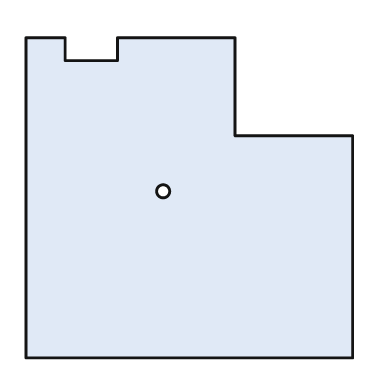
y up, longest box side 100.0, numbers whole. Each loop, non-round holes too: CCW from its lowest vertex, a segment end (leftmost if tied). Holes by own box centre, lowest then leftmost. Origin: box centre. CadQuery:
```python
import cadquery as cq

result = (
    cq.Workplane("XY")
    .moveTo(-50.0, -49.0)
    .lineTo(50.0, -49.0)
    .lineTo(50.0, 19.0)
    .lineTo(14.0, 19.0)
    .lineTo(14.0, 49.0)
    .lineTo(-22.0, 49.0)
    .lineTo(-22.0, 42.0)
    .lineTo(-38.0, 42.0)
    .lineTo(-38.0, 49.0)
    .lineTo(-50.0, 49.0)
    .close()
    .moveTo(-8.0, 2.0)
    .circle(2.0)
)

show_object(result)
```